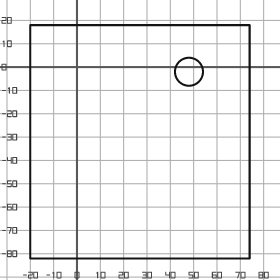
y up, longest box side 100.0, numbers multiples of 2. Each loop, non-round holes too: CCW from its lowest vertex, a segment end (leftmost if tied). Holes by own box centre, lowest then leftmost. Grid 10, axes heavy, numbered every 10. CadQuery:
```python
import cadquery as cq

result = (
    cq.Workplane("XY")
    .moveTo(-20.0, -82.0)
    .lineTo(74.0, -82.0)
    .lineTo(74.0, 18.0)
    .lineTo(-20.0, 18.0)
    .close()
    .moveTo(48.0, -2.0)
    .circle(6.0)
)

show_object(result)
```